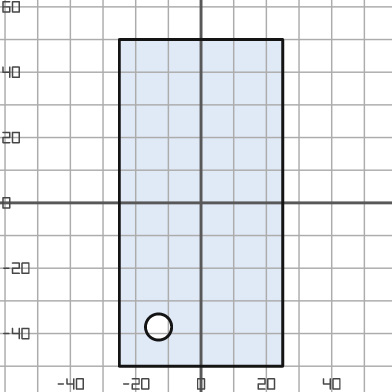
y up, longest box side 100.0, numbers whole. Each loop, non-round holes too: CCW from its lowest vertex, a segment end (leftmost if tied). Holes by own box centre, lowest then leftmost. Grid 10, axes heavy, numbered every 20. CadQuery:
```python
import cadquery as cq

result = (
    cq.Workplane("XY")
    .moveTo(-25.0, -50.0)
    .lineTo(25.0, -50.0)
    .lineTo(25.0, 50.0)
    .lineTo(-25.0, 50.0)
    .close()
    .moveTo(-13.0, -38.0)
    .circle(4.0)
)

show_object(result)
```